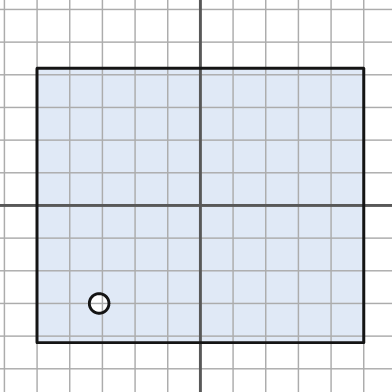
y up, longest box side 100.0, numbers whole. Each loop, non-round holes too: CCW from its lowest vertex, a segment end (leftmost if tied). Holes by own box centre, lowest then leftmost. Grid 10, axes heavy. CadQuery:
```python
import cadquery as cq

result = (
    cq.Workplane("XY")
    .moveTo(-50.0, -42.0)
    .lineTo(50.0, -42.0)
    .lineTo(50.0, 42.0)
    .lineTo(-50.0, 42.0)
    .close()
    .moveTo(-31.0, -30.0)
    .circle(3.0)
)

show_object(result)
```